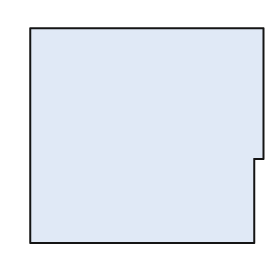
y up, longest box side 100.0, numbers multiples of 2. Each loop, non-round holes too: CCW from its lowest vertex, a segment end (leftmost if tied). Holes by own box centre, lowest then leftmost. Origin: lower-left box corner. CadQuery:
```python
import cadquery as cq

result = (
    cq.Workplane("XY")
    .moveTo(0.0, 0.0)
    .lineTo(96.0, 0.0)
    .lineTo(96.0, 36.0)
    .lineTo(100.0, 36.0)
    .lineTo(100.0, 92.0)
    .lineTo(0.0, 92.0)
    .close()
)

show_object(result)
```